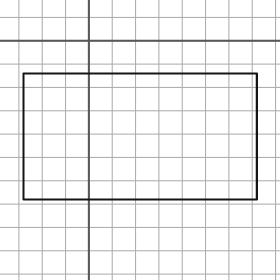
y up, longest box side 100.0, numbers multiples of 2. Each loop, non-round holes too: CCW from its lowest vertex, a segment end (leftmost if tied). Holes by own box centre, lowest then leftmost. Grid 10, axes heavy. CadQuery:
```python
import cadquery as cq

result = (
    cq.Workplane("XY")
    .moveTo(-28.0, -68.0)
    .lineTo(72.0, -68.0)
    .lineTo(72.0, -14.0)
    .lineTo(-28.0, -14.0)
    .close()
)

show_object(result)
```